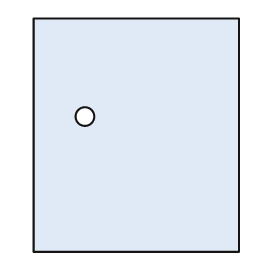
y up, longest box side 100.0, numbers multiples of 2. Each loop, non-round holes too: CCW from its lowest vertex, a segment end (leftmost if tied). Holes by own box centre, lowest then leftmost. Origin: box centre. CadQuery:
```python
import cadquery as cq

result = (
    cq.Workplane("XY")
    .moveTo(-44.0, -50.0)
    .lineTo(44.0, -50.0)
    .lineTo(44.0, 50.0)
    .lineTo(-44.0, 50.0)
    .close()
    .moveTo(-22.0, 8.0)
    .circle(4.0)
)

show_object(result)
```